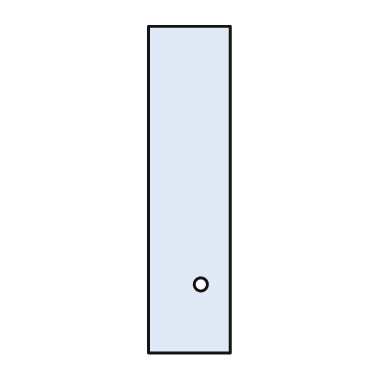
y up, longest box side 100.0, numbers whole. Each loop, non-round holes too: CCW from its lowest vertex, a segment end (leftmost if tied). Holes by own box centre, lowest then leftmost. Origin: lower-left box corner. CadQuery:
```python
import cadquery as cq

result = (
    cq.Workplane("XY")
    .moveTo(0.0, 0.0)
    .lineTo(25.0, 0.0)
    .lineTo(25.0, 100.0)
    .lineTo(0.0, 100.0)
    .close()
    .moveTo(16.0, 21.0)
    .circle(2.0)
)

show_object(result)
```